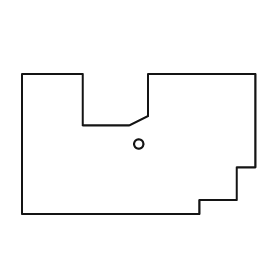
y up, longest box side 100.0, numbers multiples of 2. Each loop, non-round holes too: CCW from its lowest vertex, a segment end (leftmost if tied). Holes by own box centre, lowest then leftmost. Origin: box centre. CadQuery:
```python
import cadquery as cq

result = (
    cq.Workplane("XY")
    .moveTo(-50.0, -30.0)
    .lineTo(26.0, -30.0)
    .lineTo(26.0, -24.0)
    .lineTo(42.0, -24.0)
    .lineTo(42.0, -10.0)
    .lineTo(50.0, -10.0)
    .lineTo(50.0, 30.0)
    .lineTo(4.0, 30.0)
    .lineTo(4.0, 12.0)
    .lineTo(-4.0, 8.0)
    .lineTo(-24.0, 8.0)
    .lineTo(-24.0, 30.0)
    .lineTo(-50.0, 30.0)
    .close()
    .moveTo(0.0, 0.0)
    .circle(2.0)
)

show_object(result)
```